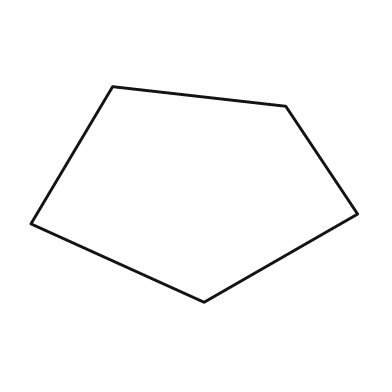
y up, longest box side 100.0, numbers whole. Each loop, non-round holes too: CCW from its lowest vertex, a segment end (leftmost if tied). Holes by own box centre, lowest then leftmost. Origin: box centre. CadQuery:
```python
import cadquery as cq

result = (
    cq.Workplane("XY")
    .moveTo(3.0, -33.0)
    .lineTo(50.0, -6.0)
    .lineTo(28.0, 27.0)
    .lineTo(-25.0, 33.0)
    .lineTo(-50.0, -9.0)
    .close()
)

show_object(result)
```